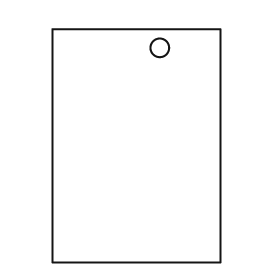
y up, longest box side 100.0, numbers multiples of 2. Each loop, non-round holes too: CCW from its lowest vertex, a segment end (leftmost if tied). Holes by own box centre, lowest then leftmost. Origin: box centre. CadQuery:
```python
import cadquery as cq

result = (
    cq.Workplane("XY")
    .moveTo(-36.0, -50.0)
    .lineTo(36.0, -50.0)
    .lineTo(36.0, 50.0)
    .lineTo(-36.0, 50.0)
    .close()
    .moveTo(10.0, 42.0)
    .circle(4.0)
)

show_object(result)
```